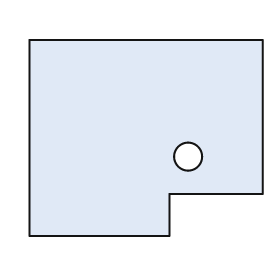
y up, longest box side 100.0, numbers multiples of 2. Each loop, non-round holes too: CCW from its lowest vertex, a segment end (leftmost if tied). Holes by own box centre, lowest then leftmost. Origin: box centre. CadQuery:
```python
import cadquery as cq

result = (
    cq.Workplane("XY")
    .moveTo(-50.0, -42.0)
    .lineTo(10.0, -42.0)
    .lineTo(10.0, -24.0)
    .lineTo(50.0, -24.0)
    .lineTo(50.0, 42.0)
    .lineTo(-50.0, 42.0)
    .close()
    .moveTo(18.0, -8.0)
    .circle(6.0)
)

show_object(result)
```